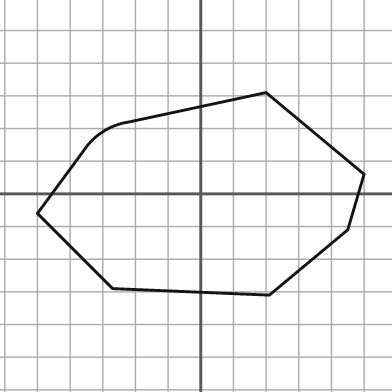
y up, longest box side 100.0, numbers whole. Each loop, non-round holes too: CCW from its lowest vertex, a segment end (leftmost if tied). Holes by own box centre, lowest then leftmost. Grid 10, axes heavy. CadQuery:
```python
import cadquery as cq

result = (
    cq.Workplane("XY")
    .moveTo(21.0, -31.0)
    .lineTo(45.0, -11.0)
    .lineTo(50.0, 6.0)
    .lineTo(20.0, 31.0)
    .lineTo(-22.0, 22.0)
    .threePointArc((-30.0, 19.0), (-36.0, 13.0))
    .lineTo(-50.0, -6.0)
    .lineTo(-27.0, -29.0)
    .close()
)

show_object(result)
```